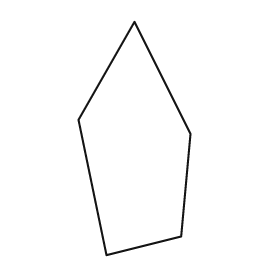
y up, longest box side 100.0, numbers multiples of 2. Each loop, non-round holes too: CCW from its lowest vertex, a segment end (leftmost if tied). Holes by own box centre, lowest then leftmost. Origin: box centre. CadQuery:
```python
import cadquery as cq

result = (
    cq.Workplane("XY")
    .moveTo(-12.0, -50.0)
    .lineTo(20.0, -42.0)
    .lineTo(24.0, 2.0)
    .lineTo(0.0, 50.0)
    .lineTo(-24.0, 8.0)
    .close()
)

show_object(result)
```